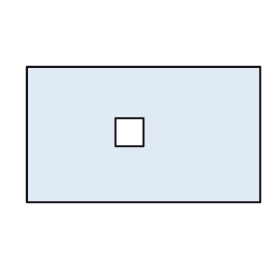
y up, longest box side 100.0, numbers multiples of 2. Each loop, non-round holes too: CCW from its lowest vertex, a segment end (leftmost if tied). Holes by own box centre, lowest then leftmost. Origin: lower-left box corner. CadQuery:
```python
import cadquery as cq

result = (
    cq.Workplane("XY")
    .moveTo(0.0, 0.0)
    .lineTo(100.0, 0.0)
    .lineTo(100.0, 58.0)
    .lineTo(0.0, 58.0)
    .close()
    .moveTo(38.0, 24.0)
    .lineTo(50.0, 24.0)
    .lineTo(50.0, 36.0)
    .lineTo(38.0, 36.0)
    .close()
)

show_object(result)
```